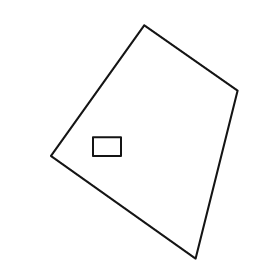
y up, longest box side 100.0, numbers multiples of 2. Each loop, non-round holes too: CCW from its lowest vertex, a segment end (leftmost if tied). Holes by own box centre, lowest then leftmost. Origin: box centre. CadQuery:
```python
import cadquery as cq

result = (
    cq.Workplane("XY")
    .moveTo(22.0, -50.0)
    .lineTo(40.0, 22.0)
    .lineTo(0.0, 50.0)
    .lineTo(-40.0, -6.0)
    .close()
    .moveTo(-22.0, -6.0)
    .lineTo(-10.0, -6.0)
    .lineTo(-10.0, 2.0)
    .lineTo(-22.0, 2.0)
    .close()
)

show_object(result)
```